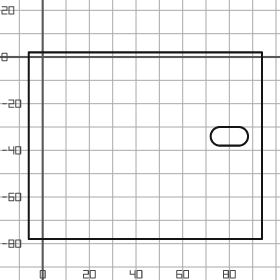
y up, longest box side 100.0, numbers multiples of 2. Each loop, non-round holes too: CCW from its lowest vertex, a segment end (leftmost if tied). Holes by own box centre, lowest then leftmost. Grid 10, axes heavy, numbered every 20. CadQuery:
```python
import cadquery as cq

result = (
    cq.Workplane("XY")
    .moveTo(-6.0, -78.0)
    .lineTo(94.0, -78.0)
    .lineTo(94.0, 2.0)
    .lineTo(-6.0, 2.0)
    .close()
    .moveTo(76.0, -38.0)
    .lineTo(84.0, -38.0)
    .threePointArc((88.0, -34.0), (84.0, -30.0))
    .lineTo(76.0, -30.0)
    .threePointArc((72.0, -34.0), (76.0, -38.0))
    .close()
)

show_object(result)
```